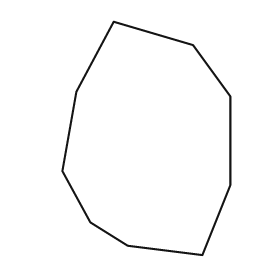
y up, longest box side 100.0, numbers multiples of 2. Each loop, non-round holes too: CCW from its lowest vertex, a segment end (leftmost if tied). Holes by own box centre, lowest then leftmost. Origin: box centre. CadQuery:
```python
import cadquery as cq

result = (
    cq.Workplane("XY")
    .moveTo(24.0, -50.0)
    .lineTo(36.0, -20.0)
    .lineTo(36.0, 18.0)
    .lineTo(20.0, 40.0)
    .lineTo(-14.0, 50.0)
    .lineTo(-30.0, 20.0)
    .lineTo(-36.0, -14.0)
    .lineTo(-24.0, -36.0)
    .lineTo(-8.0, -46.0)
    .close()
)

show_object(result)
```